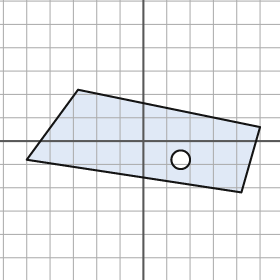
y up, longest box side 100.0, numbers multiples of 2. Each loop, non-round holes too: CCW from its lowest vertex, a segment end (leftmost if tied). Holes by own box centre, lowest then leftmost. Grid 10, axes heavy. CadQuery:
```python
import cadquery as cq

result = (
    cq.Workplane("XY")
    .moveTo(42.0, -22.0)
    .lineTo(50.0, 6.0)
    .lineTo(-28.0, 22.0)
    .lineTo(-50.0, -8.0)
    .close()
    .moveTo(16.0, -8.0)
    .circle(4.0)
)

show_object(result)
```